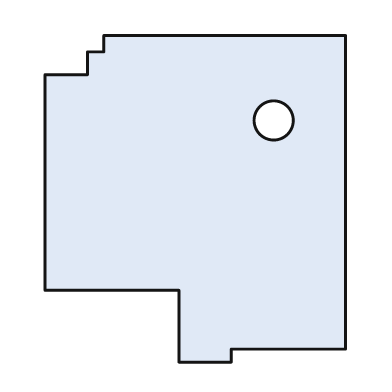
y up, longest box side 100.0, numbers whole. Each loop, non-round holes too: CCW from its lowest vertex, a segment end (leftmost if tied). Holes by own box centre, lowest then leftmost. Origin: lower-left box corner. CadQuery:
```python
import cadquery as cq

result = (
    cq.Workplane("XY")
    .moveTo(41.0, 0.0)
    .lineTo(57.0, 0.0)
    .lineTo(57.0, 4.0)
    .lineTo(92.0, 4.0)
    .lineTo(92.0, 100.0)
    .lineTo(18.0, 100.0)
    .lineTo(18.0, 95.0)
    .lineTo(13.0, 95.0)
    .lineTo(13.0, 88.0)
    .lineTo(0.0, 88.0)
    .lineTo(0.0, 22.0)
    .lineTo(41.0, 22.0)
    .close()
    .moveTo(70.0, 74.0)
    .circle(6.0)
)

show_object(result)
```